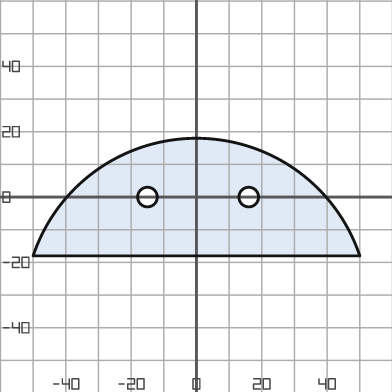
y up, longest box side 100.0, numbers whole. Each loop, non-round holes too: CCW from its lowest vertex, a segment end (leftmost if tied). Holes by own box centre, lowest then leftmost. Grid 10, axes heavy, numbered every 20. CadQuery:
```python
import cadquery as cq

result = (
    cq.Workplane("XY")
    .moveTo(-50.0, -18.0)
    .lineTo(50.0, -18.0)
    .threePointArc((0.0, 18.0), (-50.0, -18.0))
    .close()
    .moveTo(-15.0, 0.0)
    .circle(3.0)
    .moveTo(16.0, 0.0)
    .circle(3.0)
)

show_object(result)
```